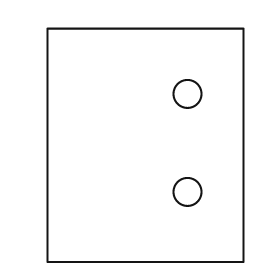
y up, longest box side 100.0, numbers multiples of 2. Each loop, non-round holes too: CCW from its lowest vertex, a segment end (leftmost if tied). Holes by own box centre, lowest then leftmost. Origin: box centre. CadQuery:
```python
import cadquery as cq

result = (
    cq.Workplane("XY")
    .moveTo(-42.0, -50.0)
    .lineTo(42.0, -50.0)
    .lineTo(42.0, 50.0)
    .lineTo(-42.0, 50.0)
    .close()
    .moveTo(18.0, -20.0)
    .circle(6.0)
    .moveTo(18.0, 22.0)
    .circle(6.0)
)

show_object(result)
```